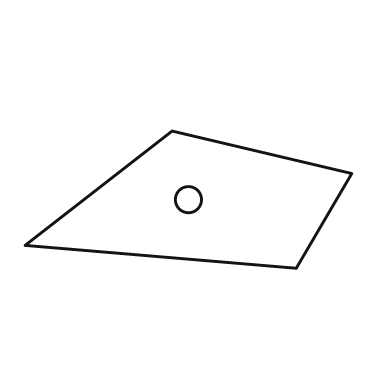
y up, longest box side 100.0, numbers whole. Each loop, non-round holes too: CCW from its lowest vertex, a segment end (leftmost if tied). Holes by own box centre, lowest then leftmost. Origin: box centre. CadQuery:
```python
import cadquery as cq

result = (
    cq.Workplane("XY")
    .moveTo(33.0, -21.0)
    .lineTo(50.0, 8.0)
    .lineTo(-5.0, 21.0)
    .lineTo(-50.0, -14.0)
    .close()
    .moveTo(0.0, 0.0)
    .circle(4.0)
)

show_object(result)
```